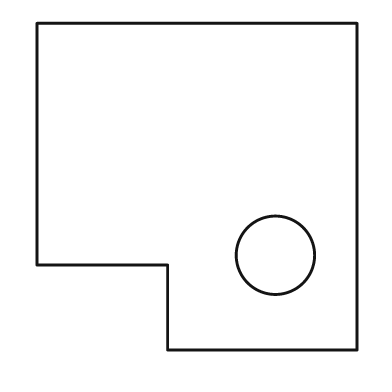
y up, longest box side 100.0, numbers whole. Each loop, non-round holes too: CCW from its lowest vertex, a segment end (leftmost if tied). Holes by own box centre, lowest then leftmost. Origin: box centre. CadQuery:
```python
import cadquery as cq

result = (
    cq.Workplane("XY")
    .moveTo(-9.0, -50.0)
    .lineTo(49.0, -50.0)
    .lineTo(49.0, 50.0)
    .lineTo(-49.0, 50.0)
    .lineTo(-49.0, -24.0)
    .lineTo(-9.0, -24.0)
    .close()
    .moveTo(24.0, -21.0)
    .circle(12.0)
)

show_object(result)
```